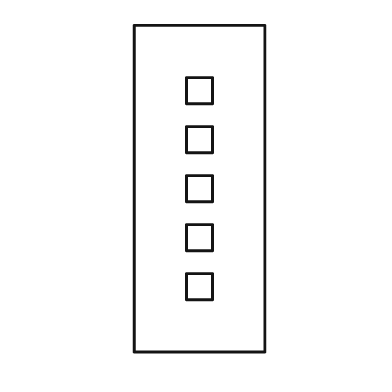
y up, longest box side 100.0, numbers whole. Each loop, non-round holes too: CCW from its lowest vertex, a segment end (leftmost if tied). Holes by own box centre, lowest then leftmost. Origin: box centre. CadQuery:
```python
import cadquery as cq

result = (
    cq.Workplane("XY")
    .moveTo(-20.0, -50.0)
    .lineTo(20.0, -50.0)
    .lineTo(20.0, 50.0)
    .lineTo(-20.0, 50.0)
    .close()
    .moveTo(-4.0, -34.0)
    .lineTo(4.0, -34.0)
    .lineTo(4.0, -26.0)
    .lineTo(-4.0, -26.0)
    .close()
    .moveTo(-4.0, -19.0)
    .lineTo(4.0, -19.0)
    .lineTo(4.0, -11.0)
    .lineTo(-4.0, -11.0)
    .close()
    .moveTo(-4.0, -4.0)
    .lineTo(4.0, -4.0)
    .lineTo(4.0, 4.0)
    .lineTo(-4.0, 4.0)
    .close()
    .moveTo(-4.0, 11.0)
    .lineTo(4.0, 11.0)
    .lineTo(4.0, 19.0)
    .lineTo(-4.0, 19.0)
    .close()
    .moveTo(-4.0, 26.0)
    .lineTo(4.0, 26.0)
    .lineTo(4.0, 34.0)
    .lineTo(-4.0, 34.0)
    .close()
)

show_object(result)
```